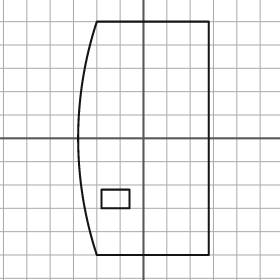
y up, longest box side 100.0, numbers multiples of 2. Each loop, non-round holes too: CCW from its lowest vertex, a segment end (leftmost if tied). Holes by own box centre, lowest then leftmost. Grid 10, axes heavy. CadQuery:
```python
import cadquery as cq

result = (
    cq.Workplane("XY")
    .moveTo(-20.0, -50.0)
    .lineTo(28.0, -50.0)
    .lineTo(28.0, 50.0)
    .lineTo(-20.0, 50.0)
    .threePointArc((-28.0, 0.0), (-20.0, -50.0))
    .close()
    .moveTo(-18.0, -30.0)
    .lineTo(-6.0, -30.0)
    .lineTo(-6.0, -22.0)
    .lineTo(-18.0, -22.0)
    .close()
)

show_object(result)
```